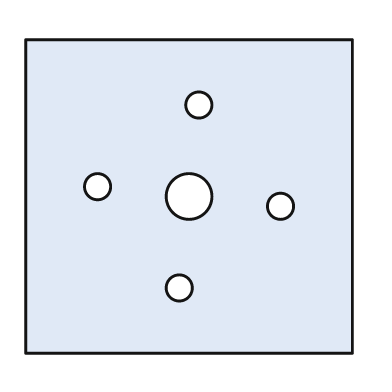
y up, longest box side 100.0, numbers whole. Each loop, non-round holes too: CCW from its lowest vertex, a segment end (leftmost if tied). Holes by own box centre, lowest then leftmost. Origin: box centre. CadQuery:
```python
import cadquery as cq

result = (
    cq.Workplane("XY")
    .moveTo(-50.0, -48.0)
    .lineTo(50.0, -48.0)
    .lineTo(50.0, 48.0)
    .lineTo(-50.0, 48.0)
    .close()
    .moveTo(-3.0, -28.0)
    .circle(4.0)
    .moveTo(28.0, -3.0)
    .circle(4.0)
    .moveTo(0.0, 0.0)
    .circle(7.0)
    .moveTo(-28.0, 3.0)
    .circle(4.0)
    .moveTo(3.0, 28.0)
    .circle(4.0)
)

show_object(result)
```